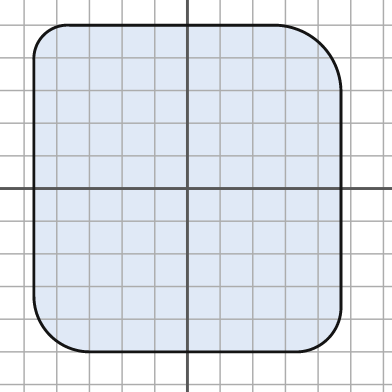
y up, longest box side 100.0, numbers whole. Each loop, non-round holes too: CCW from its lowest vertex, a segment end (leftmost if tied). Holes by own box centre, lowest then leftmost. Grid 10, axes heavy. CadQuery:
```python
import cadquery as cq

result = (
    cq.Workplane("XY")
    .moveTo(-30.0, -50.0)
    .lineTo(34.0, -50.0)
    .threePointArc((43.0, -46.0), (47.0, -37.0))
    .lineTo(47.0, 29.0)
    .threePointArc((41.0, 44.0), (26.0, 50.0))
    .lineTo(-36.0, 50.0)
    .threePointArc((-44.0, 47.0), (-47.0, 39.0))
    .lineTo(-47.0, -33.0)
    .threePointArc((-42.0, -45.0), (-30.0, -50.0))
    .close()
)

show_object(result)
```